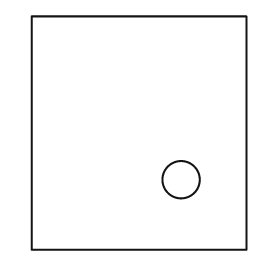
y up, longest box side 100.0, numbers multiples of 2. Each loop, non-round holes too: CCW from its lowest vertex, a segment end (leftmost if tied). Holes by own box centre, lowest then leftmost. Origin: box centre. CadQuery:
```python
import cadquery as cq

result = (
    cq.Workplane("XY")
    .moveTo(-46.0, -50.0)
    .lineTo(46.0, -50.0)
    .lineTo(46.0, 50.0)
    .lineTo(-46.0, 50.0)
    .close()
    .moveTo(18.0, -20.0)
    .circle(8.0)
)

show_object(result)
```